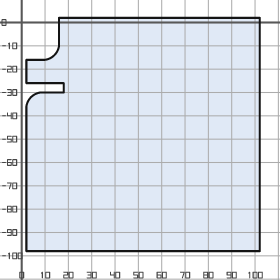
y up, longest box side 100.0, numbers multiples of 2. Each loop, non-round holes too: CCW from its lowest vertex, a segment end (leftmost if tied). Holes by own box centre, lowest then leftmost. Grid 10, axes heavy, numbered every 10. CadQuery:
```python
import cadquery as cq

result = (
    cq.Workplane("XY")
    .moveTo(2.0, -98.0)
    .lineTo(102.0, -98.0)
    .lineTo(102.0, 2.0)
    .lineTo(16.0, 2.0)
    .lineTo(16.0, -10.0)
    .threePointArc((14.0, -14.0), (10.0, -16.0))
    .lineTo(2.0, -16.0)
    .lineTo(2.0, -26.0)
    .lineTo(18.0, -26.0)
    .lineTo(18.0, -30.0)
    .lineTo(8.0, -30.0)
    .threePointArc((4.0, -32.0), (2.0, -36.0))
    .close()
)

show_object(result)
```